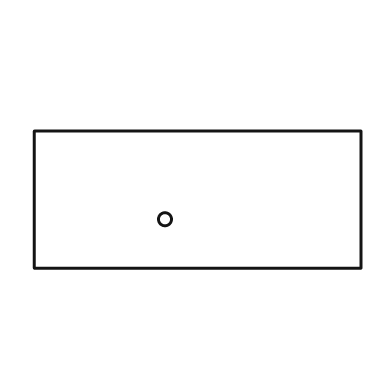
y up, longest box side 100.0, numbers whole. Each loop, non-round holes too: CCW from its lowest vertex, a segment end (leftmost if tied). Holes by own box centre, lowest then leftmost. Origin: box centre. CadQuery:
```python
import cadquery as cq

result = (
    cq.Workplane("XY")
    .moveTo(-50.0, -21.0)
    .lineTo(50.0, -21.0)
    .lineTo(50.0, 21.0)
    .lineTo(-50.0, 21.0)
    .close()
    .moveTo(-10.0, -6.0)
    .circle(2.0)
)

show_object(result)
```